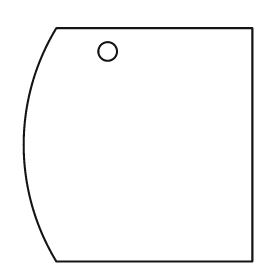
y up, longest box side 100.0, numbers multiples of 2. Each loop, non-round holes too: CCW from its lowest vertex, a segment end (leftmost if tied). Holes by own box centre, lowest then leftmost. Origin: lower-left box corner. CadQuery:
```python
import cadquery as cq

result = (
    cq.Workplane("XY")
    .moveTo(14.0, 0.0)
    .lineTo(98.0, 0.0)
    .lineTo(98.0, 100.0)
    .lineTo(14.0, 100.0)
    .threePointArc((0.0, 50.0), (14.0, 0.0))
    .close()
    .moveTo(36.0, 90.0)
    .circle(4.0)
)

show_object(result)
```